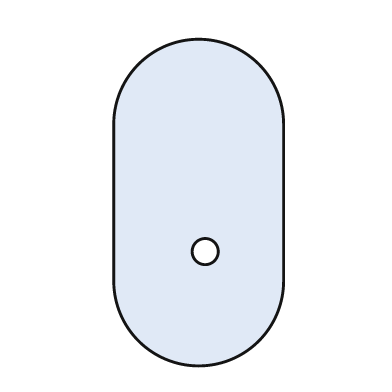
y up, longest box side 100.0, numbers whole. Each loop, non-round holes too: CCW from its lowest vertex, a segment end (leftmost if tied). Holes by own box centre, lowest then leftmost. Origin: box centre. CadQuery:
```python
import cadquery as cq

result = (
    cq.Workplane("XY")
    .moveTo(-26.0, -24.0)
    .threePointArc((0.0, -50.0), (26.0, -24.0))
    .lineTo(26.0, 24.0)
    .threePointArc((0.0, 50.0), (-26.0, 24.0))
    .close()
    .moveTo(2.0, -15.0)
    .circle(4.0)
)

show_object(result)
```